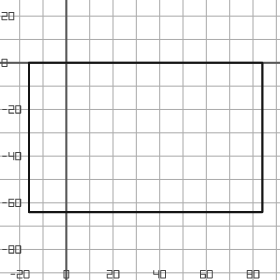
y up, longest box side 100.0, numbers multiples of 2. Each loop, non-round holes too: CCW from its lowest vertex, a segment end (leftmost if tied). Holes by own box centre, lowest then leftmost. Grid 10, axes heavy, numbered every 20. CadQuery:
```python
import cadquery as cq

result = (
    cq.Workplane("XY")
    .moveTo(-16.0, -64.0)
    .lineTo(84.0, -64.0)
    .lineTo(84.0, 0.0)
    .lineTo(-16.0, 0.0)
    .close()
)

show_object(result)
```